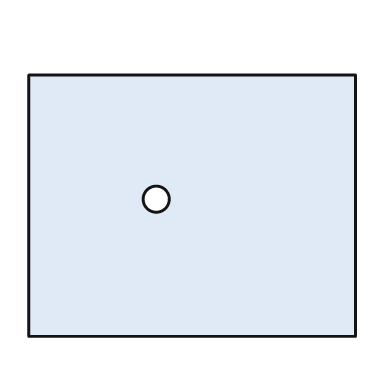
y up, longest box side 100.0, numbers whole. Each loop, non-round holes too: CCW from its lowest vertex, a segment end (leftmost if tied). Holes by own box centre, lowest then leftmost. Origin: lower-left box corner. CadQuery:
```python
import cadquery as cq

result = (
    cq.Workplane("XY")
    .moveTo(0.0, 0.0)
    .lineTo(100.0, 0.0)
    .lineTo(100.0, 80.0)
    .lineTo(0.0, 80.0)
    .close()
    .moveTo(39.0, 42.0)
    .circle(4.0)
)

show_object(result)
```